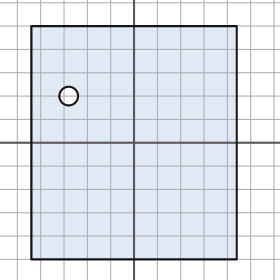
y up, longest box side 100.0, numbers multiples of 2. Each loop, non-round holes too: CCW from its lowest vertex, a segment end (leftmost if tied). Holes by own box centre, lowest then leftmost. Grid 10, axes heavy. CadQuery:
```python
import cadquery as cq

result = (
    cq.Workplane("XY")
    .moveTo(-44.0, -50.0)
    .lineTo(44.0, -50.0)
    .lineTo(44.0, 50.0)
    .lineTo(-44.0, 50.0)
    .close()
    .moveTo(-28.0, 20.0)
    .circle(4.0)
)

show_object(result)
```